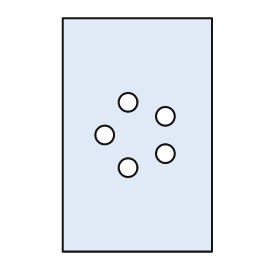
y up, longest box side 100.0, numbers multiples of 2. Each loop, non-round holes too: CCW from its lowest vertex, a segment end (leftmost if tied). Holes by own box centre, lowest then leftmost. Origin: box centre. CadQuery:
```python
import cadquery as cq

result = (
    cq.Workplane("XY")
    .moveTo(-32.0, -50.0)
    .lineTo(32.0, -50.0)
    .lineTo(32.0, 50.0)
    .lineTo(-32.0, 50.0)
    .close()
    .moveTo(-4.0, -14.0)
    .circle(4.0)
    .moveTo(12.0, -8.0)
    .circle(4.0)
    .moveTo(-14.0, 0.0)
    .circle(4.0)
    .moveTo(12.0, 8.0)
    .circle(4.0)
    .moveTo(-4.0, 14.0)
    .circle(4.0)
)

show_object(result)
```